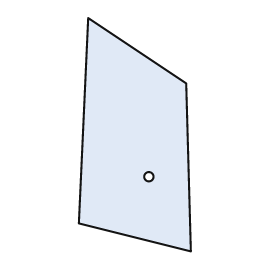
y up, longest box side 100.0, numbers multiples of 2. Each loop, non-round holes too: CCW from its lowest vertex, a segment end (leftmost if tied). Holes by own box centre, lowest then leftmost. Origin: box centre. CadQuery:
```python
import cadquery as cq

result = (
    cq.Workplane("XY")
    .moveTo(24.0, -50.0)
    .lineTo(22.0, 22.0)
    .lineTo(-20.0, 50.0)
    .lineTo(-24.0, -38.0)
    .close()
    .moveTo(6.0, -18.0)
    .circle(2.0)
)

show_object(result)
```